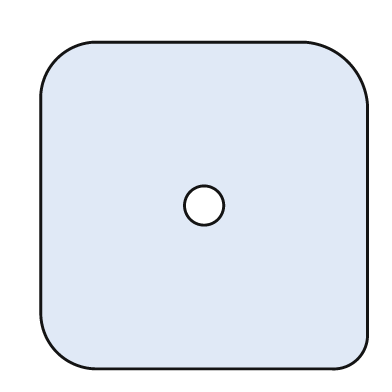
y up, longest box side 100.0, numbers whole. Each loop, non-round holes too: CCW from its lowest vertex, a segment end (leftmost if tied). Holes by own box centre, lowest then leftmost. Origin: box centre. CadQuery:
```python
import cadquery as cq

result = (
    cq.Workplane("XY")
    .moveTo(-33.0, -50.0)
    .lineTo(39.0, -50.0)
    .threePointArc((47.0, -47.0), (50.0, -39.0))
    .lineTo(50.0, 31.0)
    .threePointArc((44.0, 44.0), (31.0, 50.0))
    .lineTo(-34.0, 50.0)
    .threePointArc((-45.0, 45.0), (-50.0, 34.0))
    .lineTo(-50.0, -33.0)
    .threePointArc((-45.0, -45.0), (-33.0, -50.0))
    .close()
    .moveTo(0.0, 0.0)
    .circle(6.0)
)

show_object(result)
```